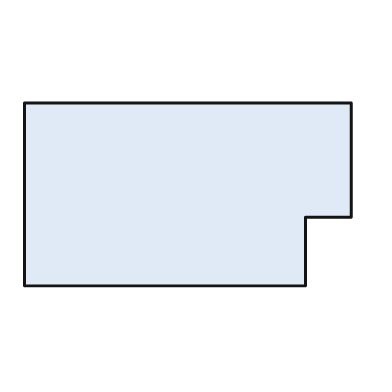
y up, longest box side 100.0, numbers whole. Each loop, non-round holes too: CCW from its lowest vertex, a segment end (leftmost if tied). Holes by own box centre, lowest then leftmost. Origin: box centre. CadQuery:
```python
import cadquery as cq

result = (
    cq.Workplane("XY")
    .moveTo(-50.0, -28.0)
    .lineTo(36.0, -28.0)
    .lineTo(36.0, -7.0)
    .lineTo(50.0, -7.0)
    .lineTo(50.0, 28.0)
    .lineTo(-50.0, 28.0)
    .close()
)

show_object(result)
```